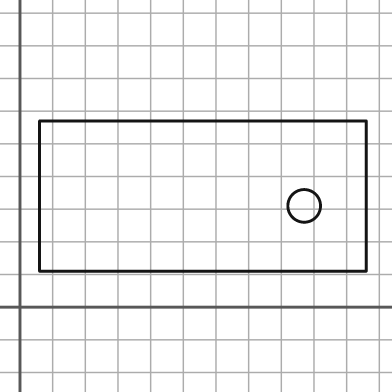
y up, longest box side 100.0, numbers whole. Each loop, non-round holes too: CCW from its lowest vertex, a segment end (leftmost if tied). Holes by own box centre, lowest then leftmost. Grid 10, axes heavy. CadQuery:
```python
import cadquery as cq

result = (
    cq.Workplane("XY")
    .moveTo(6.0, 11.0)
    .lineTo(106.0, 11.0)
    .lineTo(106.0, 57.0)
    .lineTo(6.0, 57.0)
    .close()
    .moveTo(87.0, 31.0)
    .circle(5.0)
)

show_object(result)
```